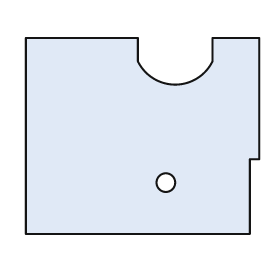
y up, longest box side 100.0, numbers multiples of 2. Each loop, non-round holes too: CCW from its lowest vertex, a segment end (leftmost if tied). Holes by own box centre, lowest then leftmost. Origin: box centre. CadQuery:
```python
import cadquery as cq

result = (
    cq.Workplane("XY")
    .moveTo(-50.0, -42.0)
    .lineTo(46.0, -42.0)
    .lineTo(46.0, -10.0)
    .lineTo(50.0, -10.0)
    .lineTo(50.0, 42.0)
    .lineTo(30.0, 42.0)
    .lineTo(30.0, 32.0)
    .threePointArc((14.0, 22.0), (-2.0, 32.0))
    .lineTo(-2.0, 42.0)
    .lineTo(-50.0, 42.0)
    .close()
    .moveTo(10.0, -20.0)
    .circle(4.0)
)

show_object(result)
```